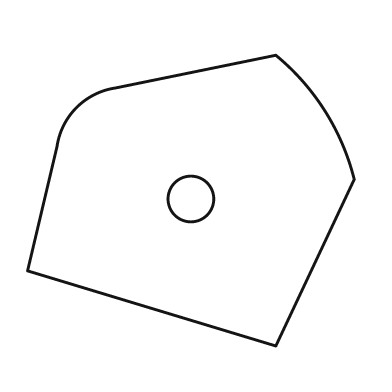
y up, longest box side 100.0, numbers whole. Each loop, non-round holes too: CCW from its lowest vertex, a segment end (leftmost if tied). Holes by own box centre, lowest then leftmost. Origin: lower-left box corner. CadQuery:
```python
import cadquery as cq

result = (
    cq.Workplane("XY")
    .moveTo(76.0, 0.0)
    .lineTo(100.0, 51.0)
    .threePointArc((91.0, 72.0), (76.0, 89.0))
    .lineTo(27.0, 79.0)
    .threePointArc((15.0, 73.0), (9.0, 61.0))
    .lineTo(0.0, 23.0)
    .close()
    .moveTo(50.0, 45.0)
    .circle(7.0)
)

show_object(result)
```